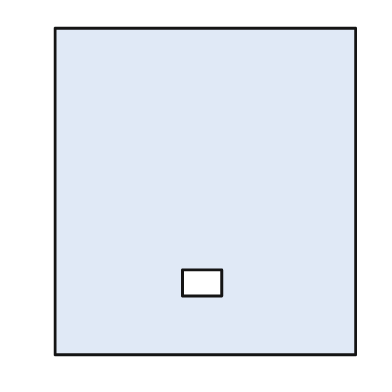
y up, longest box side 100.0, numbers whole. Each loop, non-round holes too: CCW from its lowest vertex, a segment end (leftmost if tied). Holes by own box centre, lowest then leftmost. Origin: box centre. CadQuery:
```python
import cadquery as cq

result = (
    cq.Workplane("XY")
    .moveTo(-46.0, -50.0)
    .lineTo(46.0, -50.0)
    .lineTo(46.0, 50.0)
    .lineTo(-46.0, 50.0)
    .close()
    .moveTo(-7.0, -32.0)
    .lineTo(5.0, -32.0)
    .lineTo(5.0, -24.0)
    .lineTo(-7.0, -24.0)
    .close()
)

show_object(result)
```